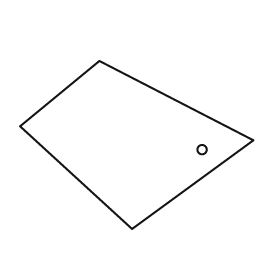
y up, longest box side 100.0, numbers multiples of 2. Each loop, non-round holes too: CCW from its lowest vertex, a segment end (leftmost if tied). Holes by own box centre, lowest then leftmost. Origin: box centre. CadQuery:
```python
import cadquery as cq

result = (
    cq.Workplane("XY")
    .moveTo(-2.0, -36.0)
    .lineTo(50.0, 2.0)
    .lineTo(-16.0, 36.0)
    .lineTo(-50.0, 8.0)
    .close()
    .moveTo(28.0, -2.0)
    .circle(2.0)
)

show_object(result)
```